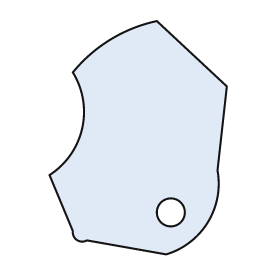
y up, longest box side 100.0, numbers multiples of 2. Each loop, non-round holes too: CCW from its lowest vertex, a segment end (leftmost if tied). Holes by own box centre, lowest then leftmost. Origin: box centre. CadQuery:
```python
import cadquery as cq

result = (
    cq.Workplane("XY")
    .moveTo(12.0, -50.0)
    .threePointArc((30.0, -36.0), (34.0, -14.0))
    .lineTo(38.0, 22.0)
    .lineTo(8.0, 50.0)
    .threePointArc((-12.0, 42.0), (-28.0, 28.0))
    .threePointArc((-24.0, 4.0), (-38.0, -16.0))
    .lineTo(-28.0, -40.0)
    .threePointArc((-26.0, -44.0), (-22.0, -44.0))
    .close()
    .moveTo(14.0, -32.0)
    .circle(6.0)
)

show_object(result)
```